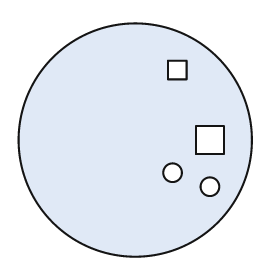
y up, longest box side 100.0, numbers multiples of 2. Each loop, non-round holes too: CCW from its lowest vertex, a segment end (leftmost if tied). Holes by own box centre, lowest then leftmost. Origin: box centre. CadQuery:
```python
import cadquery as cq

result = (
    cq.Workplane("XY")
    .moveTo(0.0, 0.0)
    .circle(50.0)
    .moveTo(32.0, -20.0)
    .circle(4.0)
    .moveTo(16.0, -14.0)
    .circle(4.0)
    .moveTo(26.0, -6.0)
    .lineTo(38.0, -6.0)
    .lineTo(38.0, 6.0)
    .lineTo(26.0, 6.0)
    .close()
    .moveTo(14.0, 26.0)
    .lineTo(22.0, 26.0)
    .lineTo(22.0, 34.0)
    .lineTo(14.0, 34.0)
    .close()
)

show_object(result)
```